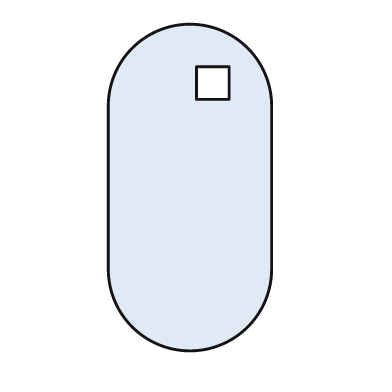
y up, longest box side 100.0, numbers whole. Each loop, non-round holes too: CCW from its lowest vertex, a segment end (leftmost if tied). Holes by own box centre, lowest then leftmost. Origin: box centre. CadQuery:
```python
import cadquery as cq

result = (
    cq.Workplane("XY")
    .moveTo(-25.0, -25.0)
    .threePointArc((0.0, -50.0), (25.0, -25.0))
    .lineTo(25.0, 25.0)
    .threePointArc((0.0, 50.0), (-25.0, 25.0))
    .close()
    .moveTo(2.0, 27.0)
    .lineTo(12.0, 27.0)
    .lineTo(12.0, 37.0)
    .lineTo(2.0, 37.0)
    .close()
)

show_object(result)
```